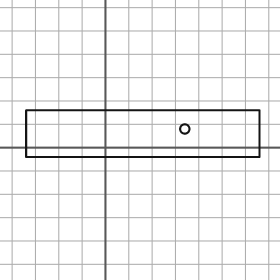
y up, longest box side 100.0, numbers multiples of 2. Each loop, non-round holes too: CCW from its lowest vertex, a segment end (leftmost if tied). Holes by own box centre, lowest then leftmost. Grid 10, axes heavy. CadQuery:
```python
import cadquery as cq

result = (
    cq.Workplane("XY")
    .moveTo(-34.0, -4.0)
    .lineTo(66.0, -4.0)
    .lineTo(66.0, 16.0)
    .lineTo(-34.0, 16.0)
    .close()
    .moveTo(34.0, 8.0)
    .circle(2.0)
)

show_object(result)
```